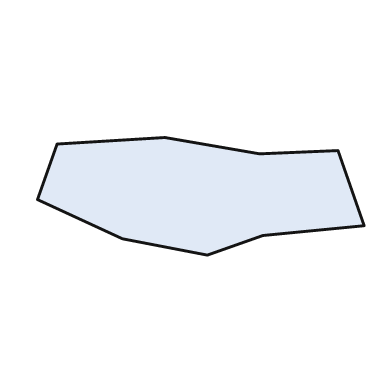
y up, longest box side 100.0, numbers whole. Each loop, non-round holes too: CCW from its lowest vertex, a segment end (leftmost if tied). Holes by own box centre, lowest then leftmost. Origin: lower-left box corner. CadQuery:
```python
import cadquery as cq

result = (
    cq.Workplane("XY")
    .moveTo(52.0, 0.0)
    .lineTo(69.0, 6.0)
    .lineTo(100.0, 9.0)
    .lineTo(92.0, 32.0)
    .lineTo(68.0, 31.0)
    .lineTo(39.0, 36.0)
    .lineTo(6.0, 34.0)
    .lineTo(0.0, 17.0)
    .lineTo(26.0, 5.0)
    .close()
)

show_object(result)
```